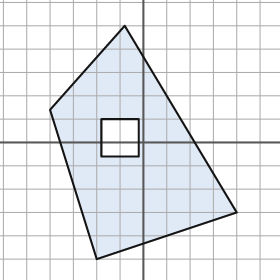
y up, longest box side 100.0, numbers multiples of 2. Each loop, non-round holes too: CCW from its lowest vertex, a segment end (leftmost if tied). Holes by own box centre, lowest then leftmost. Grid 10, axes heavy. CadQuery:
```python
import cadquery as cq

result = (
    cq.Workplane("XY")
    .moveTo(-20.0, -50.0)
    .lineTo(40.0, -30.0)
    .lineTo(-8.0, 50.0)
    .lineTo(-40.0, 14.0)
    .close()
    .moveTo(-18.0, -6.0)
    .lineTo(-2.0, -6.0)
    .lineTo(-2.0, 10.0)
    .lineTo(-18.0, 10.0)
    .close()
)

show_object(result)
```